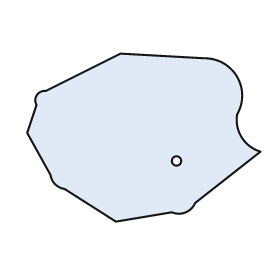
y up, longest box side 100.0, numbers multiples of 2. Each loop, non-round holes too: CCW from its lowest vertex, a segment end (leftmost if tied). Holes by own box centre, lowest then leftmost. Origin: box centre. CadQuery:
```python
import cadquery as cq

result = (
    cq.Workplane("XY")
    .moveTo(-12.0, -36.0)
    .lineTo(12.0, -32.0)
    .threePointArc((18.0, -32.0), (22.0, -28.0))
    .lineTo(50.0, -6.0)
    .threePointArc((42.0, 0.0), (40.0, 10.0))
    .threePointArc((40.0, 26.0), (26.0, 34.0))
    .lineTo(-10.0, 36.0)
    .lineTo(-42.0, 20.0)
    .threePointArc((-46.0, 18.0), (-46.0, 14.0))
    .lineTo(-50.0, 2.0)
    .lineTo(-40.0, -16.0)
    .threePointArc((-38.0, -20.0), (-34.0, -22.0))
    .close()
    .moveTo(14.0, -10.0)
    .circle(2.0)
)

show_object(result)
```